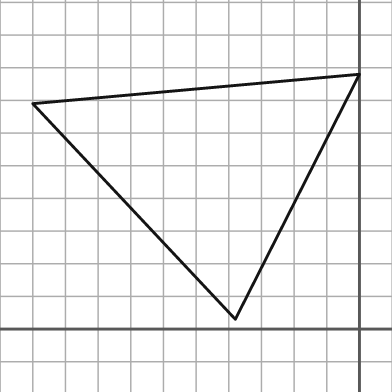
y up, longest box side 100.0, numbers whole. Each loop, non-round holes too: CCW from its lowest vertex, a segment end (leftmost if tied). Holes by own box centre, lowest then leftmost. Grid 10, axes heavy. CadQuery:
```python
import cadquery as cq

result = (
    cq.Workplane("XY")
    .moveTo(-38.0, 3.0)
    .lineTo(0.0, 78.0)
    .lineTo(-100.0, 69.0)
    .close()
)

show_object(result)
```